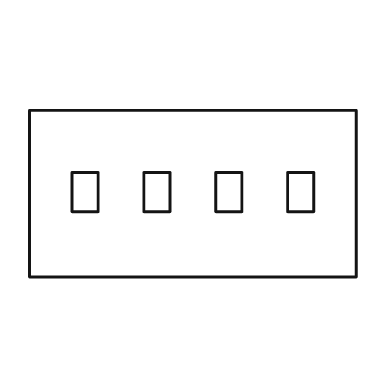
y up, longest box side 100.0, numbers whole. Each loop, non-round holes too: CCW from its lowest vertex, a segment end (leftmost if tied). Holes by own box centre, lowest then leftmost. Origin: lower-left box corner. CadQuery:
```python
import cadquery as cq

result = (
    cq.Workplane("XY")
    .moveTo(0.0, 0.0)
    .lineTo(100.0, 0.0)
    .lineTo(100.0, 51.0)
    .lineTo(0.0, 51.0)
    .close()
    .moveTo(13.0, 20.0)
    .lineTo(21.0, 20.0)
    .lineTo(21.0, 32.0)
    .lineTo(13.0, 32.0)
    .close()
    .moveTo(35.0, 20.0)
    .lineTo(43.0, 20.0)
    .lineTo(43.0, 32.0)
    .lineTo(35.0, 32.0)
    .close()
    .moveTo(57.0, 20.0)
    .lineTo(65.0, 20.0)
    .lineTo(65.0, 32.0)
    .lineTo(57.0, 32.0)
    .close()
    .moveTo(79.0, 20.0)
    .lineTo(87.0, 20.0)
    .lineTo(87.0, 32.0)
    .lineTo(79.0, 32.0)
    .close()
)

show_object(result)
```